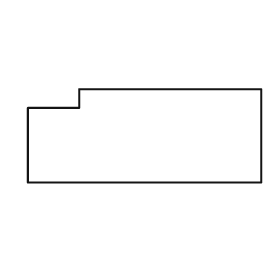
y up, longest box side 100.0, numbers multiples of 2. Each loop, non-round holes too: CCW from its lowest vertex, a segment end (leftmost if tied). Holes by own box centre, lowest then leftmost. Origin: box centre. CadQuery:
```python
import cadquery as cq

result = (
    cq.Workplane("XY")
    .moveTo(-50.0, -20.0)
    .lineTo(50.0, -20.0)
    .lineTo(50.0, 20.0)
    .lineTo(-28.0, 20.0)
    .lineTo(-28.0, 12.0)
    .lineTo(-50.0, 12.0)
    .close()
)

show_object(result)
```